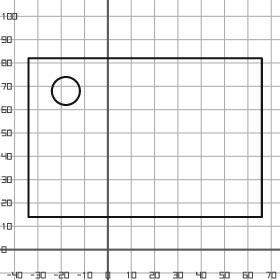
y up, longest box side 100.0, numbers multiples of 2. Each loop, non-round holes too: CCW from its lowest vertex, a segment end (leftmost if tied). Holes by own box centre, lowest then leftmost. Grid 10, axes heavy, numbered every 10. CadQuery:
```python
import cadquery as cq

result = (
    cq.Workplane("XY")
    .moveTo(-34.0, 14.0)
    .lineTo(66.0, 14.0)
    .lineTo(66.0, 82.0)
    .lineTo(-34.0, 82.0)
    .close()
    .moveTo(-18.0, 68.0)
    .circle(6.0)
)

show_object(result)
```